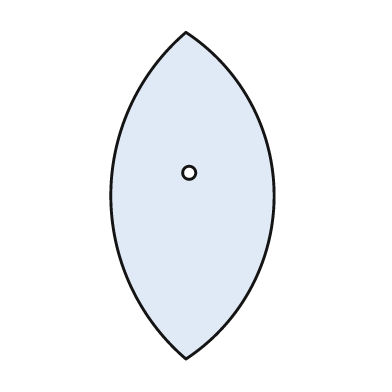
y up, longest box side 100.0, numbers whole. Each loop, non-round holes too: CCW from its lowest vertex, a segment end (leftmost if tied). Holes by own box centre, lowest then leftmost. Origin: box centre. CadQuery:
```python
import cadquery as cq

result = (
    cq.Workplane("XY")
    .moveTo(-2.0, -50.0)
    .threePointArc((25.0, 0.0), (-2.0, 50.0))
    .threePointArc((-25.0, 0.0), (-2.0, -50.0))
    .close()
    .moveTo(-1.0, 7.0)
    .circle(2.0)
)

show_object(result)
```